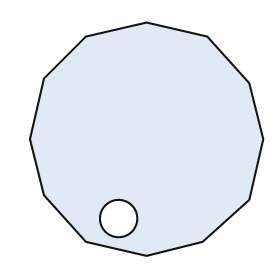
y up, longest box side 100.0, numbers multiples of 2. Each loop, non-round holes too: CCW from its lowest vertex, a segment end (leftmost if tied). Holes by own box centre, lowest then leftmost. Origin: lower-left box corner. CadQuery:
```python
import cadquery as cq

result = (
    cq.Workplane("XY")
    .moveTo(50.0, 0.0)
    .lineTo(74.0, 6.0)
    .lineTo(94.0, 24.0)
    .lineTo(100.0, 50.0)
    .lineTo(94.0, 74.0)
    .lineTo(76.0, 94.0)
    .lineTo(50.0, 100.0)
    .lineTo(24.0, 94.0)
    .lineTo(6.0, 76.0)
    .lineTo(0.0, 50.0)
    .lineTo(6.0, 26.0)
    .lineTo(24.0, 6.0)
    .close()
    .moveTo(38.0, 16.0)
    .circle(8.0)
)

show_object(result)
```